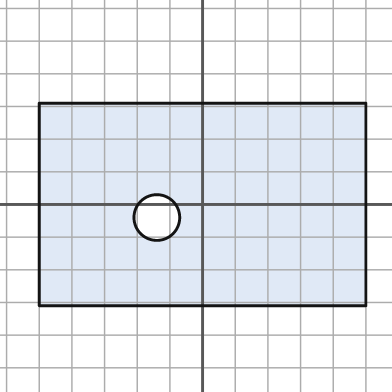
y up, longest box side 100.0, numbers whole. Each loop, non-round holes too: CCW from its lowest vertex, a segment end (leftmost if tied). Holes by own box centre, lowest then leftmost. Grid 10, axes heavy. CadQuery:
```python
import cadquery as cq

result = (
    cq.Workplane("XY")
    .moveTo(-50.0, -31.0)
    .lineTo(50.0, -31.0)
    .lineTo(50.0, 31.0)
    .lineTo(-50.0, 31.0)
    .close()
    .moveTo(-14.0, -4.0)
    .circle(7.0)
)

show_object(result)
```